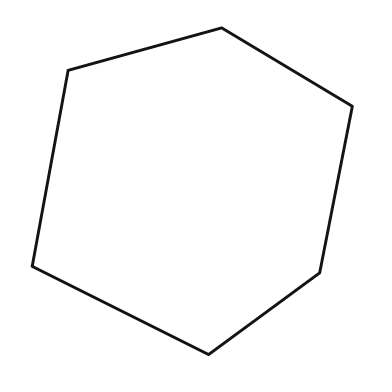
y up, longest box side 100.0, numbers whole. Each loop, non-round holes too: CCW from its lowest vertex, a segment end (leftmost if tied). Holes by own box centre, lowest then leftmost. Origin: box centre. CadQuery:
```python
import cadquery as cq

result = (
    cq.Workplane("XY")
    .moveTo(5.0, -50.0)
    .lineTo(39.0, -25.0)
    .lineTo(49.0, 26.0)
    .lineTo(9.0, 50.0)
    .lineTo(-38.0, 37.0)
    .lineTo(-49.0, -23.0)
    .close()
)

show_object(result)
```